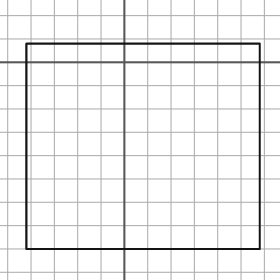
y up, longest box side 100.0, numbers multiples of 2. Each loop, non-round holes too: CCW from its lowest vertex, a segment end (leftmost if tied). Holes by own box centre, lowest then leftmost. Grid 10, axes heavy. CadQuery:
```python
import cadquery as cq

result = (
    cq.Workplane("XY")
    .moveTo(-42.0, -80.0)
    .lineTo(58.0, -80.0)
    .lineTo(58.0, 8.0)
    .lineTo(-42.0, 8.0)
    .close()
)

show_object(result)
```